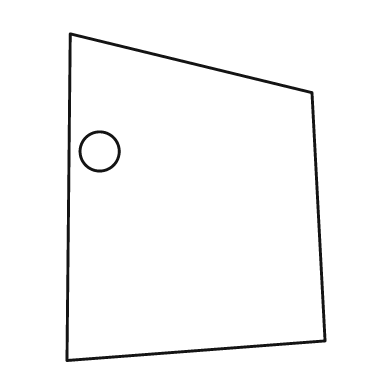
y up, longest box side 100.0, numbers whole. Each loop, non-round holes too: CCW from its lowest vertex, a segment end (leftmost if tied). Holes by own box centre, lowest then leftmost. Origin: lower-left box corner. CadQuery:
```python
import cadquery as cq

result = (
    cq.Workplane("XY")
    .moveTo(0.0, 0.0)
    .lineTo(79.0, 6.0)
    .lineTo(75.0, 82.0)
    .lineTo(1.0, 100.0)
    .close()
    .moveTo(10.0, 64.0)
    .circle(6.0)
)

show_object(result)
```